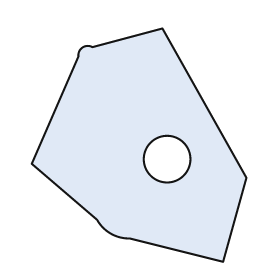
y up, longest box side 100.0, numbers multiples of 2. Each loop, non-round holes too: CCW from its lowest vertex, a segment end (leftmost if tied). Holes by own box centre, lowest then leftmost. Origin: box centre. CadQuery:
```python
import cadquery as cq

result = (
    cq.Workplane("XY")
    .moveTo(36.0, -50.0)
    .lineTo(46.0, -14.0)
    .lineTo(10.0, 50.0)
    .lineTo(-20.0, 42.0)
    .threePointArc((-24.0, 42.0), (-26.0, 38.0))
    .lineTo(-46.0, -8.0)
    .lineTo(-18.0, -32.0)
    .threePointArc((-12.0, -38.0), (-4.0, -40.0))
    .close()
    .moveTo(12.0, -6.0)
    .circle(10.0)
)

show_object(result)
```